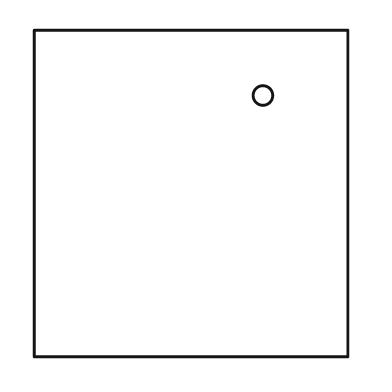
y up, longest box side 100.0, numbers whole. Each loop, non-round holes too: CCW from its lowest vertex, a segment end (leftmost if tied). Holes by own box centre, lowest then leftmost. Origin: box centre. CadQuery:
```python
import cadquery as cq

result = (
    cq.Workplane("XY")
    .moveTo(-48.0, -50.0)
    .lineTo(48.0, -50.0)
    .lineTo(48.0, 50.0)
    .lineTo(-48.0, 50.0)
    .close()
    .moveTo(22.0, 30.0)
    .circle(3.0)
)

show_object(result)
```